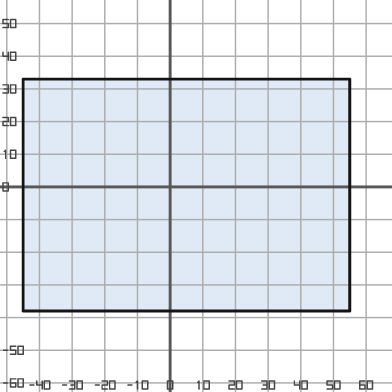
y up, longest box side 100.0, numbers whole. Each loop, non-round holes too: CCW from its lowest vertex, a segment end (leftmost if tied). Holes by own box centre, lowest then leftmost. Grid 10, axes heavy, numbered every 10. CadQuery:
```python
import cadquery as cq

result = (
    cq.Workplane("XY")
    .moveTo(-45.0, -38.0)
    .lineTo(55.0, -38.0)
    .lineTo(55.0, 33.0)
    .lineTo(-45.0, 33.0)
    .close()
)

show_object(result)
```